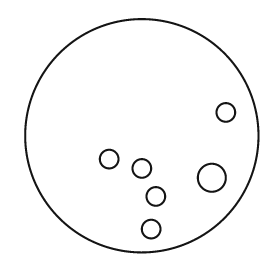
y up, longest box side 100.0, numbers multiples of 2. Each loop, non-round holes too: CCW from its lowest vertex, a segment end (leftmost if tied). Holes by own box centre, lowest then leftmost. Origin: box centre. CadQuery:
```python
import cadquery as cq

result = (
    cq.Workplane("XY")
    .moveTo(0.0, 0.0)
    .circle(50.0)
    .moveTo(4.0, -40.0)
    .circle(4.0)
    .moveTo(6.0, -26.0)
    .circle(4.0)
    .moveTo(30.0, -18.0)
    .circle(6.0)
    .moveTo(0.0, -14.0)
    .circle(4.0)
    .moveTo(-14.0, -10.0)
    .circle(4.0)
    .moveTo(36.0, 10.0)
    .circle(4.0)
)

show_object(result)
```